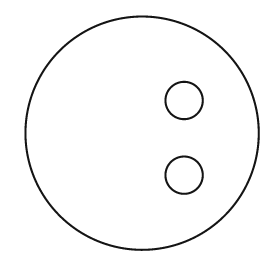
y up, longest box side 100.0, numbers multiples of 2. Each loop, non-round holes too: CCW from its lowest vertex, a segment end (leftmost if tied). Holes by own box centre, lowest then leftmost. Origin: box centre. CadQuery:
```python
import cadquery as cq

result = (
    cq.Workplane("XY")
    .moveTo(0.0, 0.0)
    .circle(50.0)
    .moveTo(18.0, -18.0)
    .circle(8.0)
    .moveTo(18.0, 14.0)
    .circle(8.0)
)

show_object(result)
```